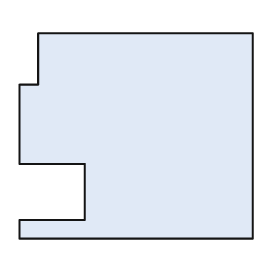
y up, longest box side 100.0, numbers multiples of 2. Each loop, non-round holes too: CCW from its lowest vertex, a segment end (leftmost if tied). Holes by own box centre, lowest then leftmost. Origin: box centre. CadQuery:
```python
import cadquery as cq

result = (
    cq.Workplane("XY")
    .moveTo(-50.0, -44.0)
    .lineTo(50.0, -44.0)
    .lineTo(50.0, 44.0)
    .lineTo(-42.0, 44.0)
    .lineTo(-42.0, 22.0)
    .lineTo(-50.0, 22.0)
    .lineTo(-50.0, -12.0)
    .lineTo(-22.0, -12.0)
    .lineTo(-22.0, -36.0)
    .lineTo(-50.0, -36.0)
    .close()
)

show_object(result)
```